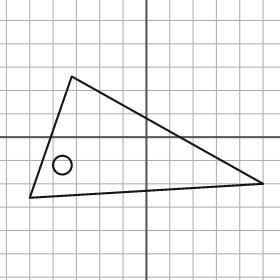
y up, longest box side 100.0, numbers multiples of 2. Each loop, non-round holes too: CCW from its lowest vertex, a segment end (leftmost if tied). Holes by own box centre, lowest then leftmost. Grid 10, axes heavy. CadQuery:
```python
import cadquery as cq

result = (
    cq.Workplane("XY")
    .moveTo(-50.0, -26.0)
    .lineTo(50.0, -20.0)
    .lineTo(-32.0, 26.0)
    .close()
    .moveTo(-36.0, -12.0)
    .circle(4.0)
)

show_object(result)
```